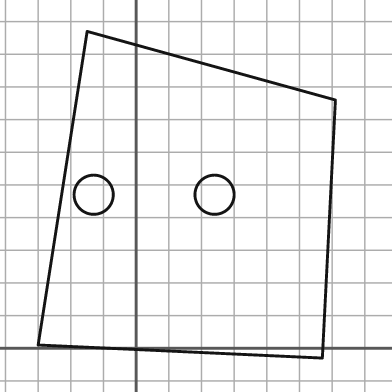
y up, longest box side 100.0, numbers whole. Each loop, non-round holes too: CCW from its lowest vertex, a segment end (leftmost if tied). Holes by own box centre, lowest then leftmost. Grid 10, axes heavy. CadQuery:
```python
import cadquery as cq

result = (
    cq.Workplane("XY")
    .moveTo(57.0, -3.0)
    .lineTo(61.0, 76.0)
    .lineTo(-15.0, 97.0)
    .lineTo(-30.0, 1.0)
    .close()
    .moveTo(-13.0, 47.0)
    .circle(6.0)
    .moveTo(24.0, 47.0)
    .circle(6.0)
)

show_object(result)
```